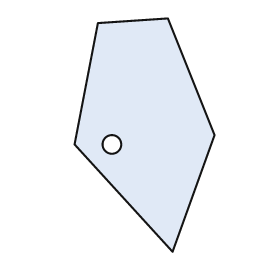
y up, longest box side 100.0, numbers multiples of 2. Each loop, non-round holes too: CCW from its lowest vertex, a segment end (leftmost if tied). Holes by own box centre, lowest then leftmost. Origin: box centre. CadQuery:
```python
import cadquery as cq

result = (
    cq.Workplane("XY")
    .moveTo(12.0, -50.0)
    .lineTo(30.0, 0.0)
    .lineTo(10.0, 50.0)
    .lineTo(-20.0, 48.0)
    .lineTo(-30.0, -4.0)
    .close()
    .moveTo(-14.0, -4.0)
    .circle(4.0)
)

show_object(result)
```